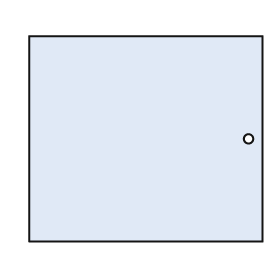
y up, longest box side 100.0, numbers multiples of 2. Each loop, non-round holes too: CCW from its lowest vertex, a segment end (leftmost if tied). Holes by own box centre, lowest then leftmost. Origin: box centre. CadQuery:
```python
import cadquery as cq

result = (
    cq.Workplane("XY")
    .moveTo(-50.0, -44.0)
    .lineTo(50.0, -44.0)
    .lineTo(50.0, 44.0)
    .lineTo(-50.0, 44.0)
    .close()
    .moveTo(44.0, 0.0)
    .circle(2.0)
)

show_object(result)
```